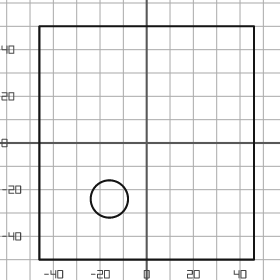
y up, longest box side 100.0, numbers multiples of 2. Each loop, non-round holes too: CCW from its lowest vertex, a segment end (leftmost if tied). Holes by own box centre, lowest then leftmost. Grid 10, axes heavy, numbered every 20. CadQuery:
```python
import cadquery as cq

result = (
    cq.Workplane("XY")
    .moveTo(-46.0, -50.0)
    .lineTo(46.0, -50.0)
    .lineTo(46.0, 50.0)
    .lineTo(-46.0, 50.0)
    .close()
    .moveTo(-16.0, -24.0)
    .circle(8.0)
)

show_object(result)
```